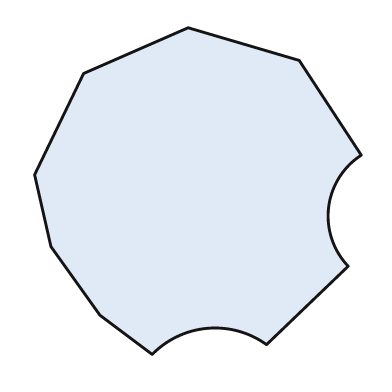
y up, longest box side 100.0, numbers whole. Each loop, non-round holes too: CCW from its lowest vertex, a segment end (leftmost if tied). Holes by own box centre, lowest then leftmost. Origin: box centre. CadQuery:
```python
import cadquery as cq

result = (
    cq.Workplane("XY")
    .moveTo(-14.0, -50.0)
    .threePointArc((3.0, -42.0), (21.0, -47.0))
    .lineTo(46.0, -23.0)
    .threePointArc((40.0, -5.0), (50.0, 11.0))
    .lineTo(31.0, 40.0)
    .lineTo(-3.0, 50.0)
    .lineTo(-35.0, 36.0)
    .lineTo(-50.0, 5.0)
    .lineTo(-45.0, -17.0)
    .lineTo(-30.0, -38.0)
    .close()
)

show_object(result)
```